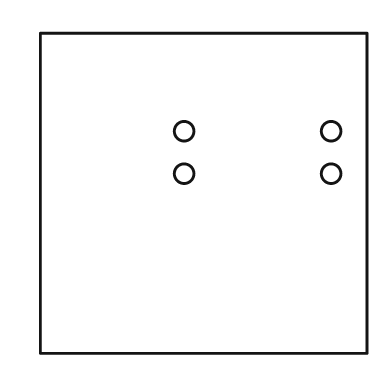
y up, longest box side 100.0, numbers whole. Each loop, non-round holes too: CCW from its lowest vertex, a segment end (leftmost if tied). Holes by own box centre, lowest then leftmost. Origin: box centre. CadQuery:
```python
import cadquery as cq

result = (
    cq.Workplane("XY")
    .moveTo(-50.0, -49.0)
    .lineTo(50.0, -49.0)
    .lineTo(50.0, 49.0)
    .lineTo(-50.0, 49.0)
    .close()
    .moveTo(-6.0, 6.0)
    .circle(3.0)
    .moveTo(39.0, 6.0)
    .circle(3.0)
    .moveTo(-6.0, 19.0)
    .circle(3.0)
    .moveTo(39.0, 19.0)
    .circle(3.0)
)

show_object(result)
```